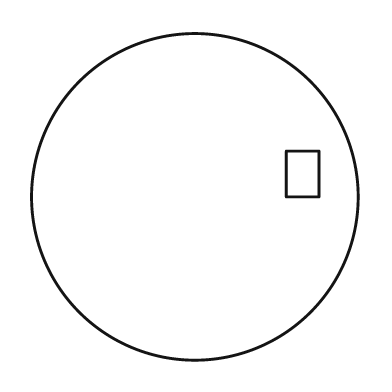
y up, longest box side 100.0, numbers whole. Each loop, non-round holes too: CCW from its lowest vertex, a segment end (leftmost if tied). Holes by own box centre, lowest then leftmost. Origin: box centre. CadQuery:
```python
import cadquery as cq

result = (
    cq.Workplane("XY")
    .moveTo(0.0, 0.0)
    .circle(50.0)
    .moveTo(28.0, 0.0)
    .lineTo(38.0, 0.0)
    .lineTo(38.0, 14.0)
    .lineTo(28.0, 14.0)
    .close()
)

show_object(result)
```